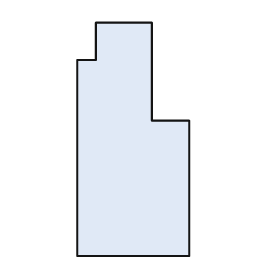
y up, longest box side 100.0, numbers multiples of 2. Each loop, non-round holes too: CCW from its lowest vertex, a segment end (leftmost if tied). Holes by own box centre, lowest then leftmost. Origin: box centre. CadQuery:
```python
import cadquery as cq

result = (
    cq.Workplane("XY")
    .moveTo(-24.0, -50.0)
    .lineTo(24.0, -50.0)
    .lineTo(24.0, 8.0)
    .lineTo(8.0, 8.0)
    .lineTo(8.0, 50.0)
    .lineTo(-16.0, 50.0)
    .lineTo(-16.0, 34.0)
    .lineTo(-24.0, 34.0)
    .close()
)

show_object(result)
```